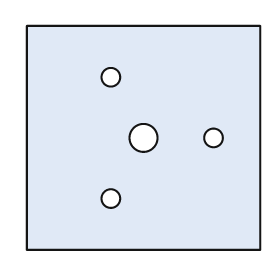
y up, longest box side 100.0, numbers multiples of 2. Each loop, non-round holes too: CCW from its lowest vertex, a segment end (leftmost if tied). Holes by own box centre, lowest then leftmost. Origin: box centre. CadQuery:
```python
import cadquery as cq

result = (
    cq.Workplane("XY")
    .moveTo(-50.0, -48.0)
    .lineTo(50.0, -48.0)
    .lineTo(50.0, 48.0)
    .lineTo(-50.0, 48.0)
    .close()
    .moveTo(-14.0, -26.0)
    .circle(4.0)
    .moveTo(0.0, 0.0)
    .circle(6.0)
    .moveTo(30.0, 0.0)
    .circle(4.0)
    .moveTo(-14.0, 26.0)
    .circle(4.0)
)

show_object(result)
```